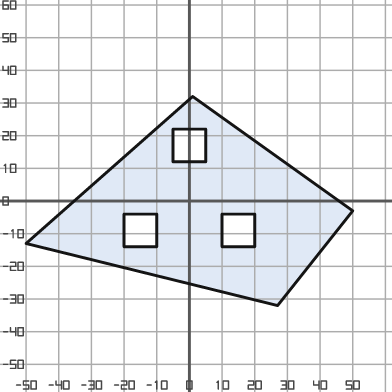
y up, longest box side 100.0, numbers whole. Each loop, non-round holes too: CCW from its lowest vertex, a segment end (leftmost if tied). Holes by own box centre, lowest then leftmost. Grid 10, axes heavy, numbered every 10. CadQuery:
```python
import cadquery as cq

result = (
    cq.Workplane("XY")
    .moveTo(27.0, -32.0)
    .lineTo(50.0, -3.0)
    .lineTo(1.0, 32.0)
    .lineTo(-50.0, -13.0)
    .close()
    .moveTo(-20.0, -14.0)
    .lineTo(-10.0, -14.0)
    .lineTo(-10.0, -4.0)
    .lineTo(-20.0, -4.0)
    .close()
    .moveTo(10.0, -14.0)
    .lineTo(20.0, -14.0)
    .lineTo(20.0, -4.0)
    .lineTo(10.0, -4.0)
    .close()
    .moveTo(-5.0, 12.0)
    .lineTo(5.0, 12.0)
    .lineTo(5.0, 22.0)
    .lineTo(-5.0, 22.0)
    .close()
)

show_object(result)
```